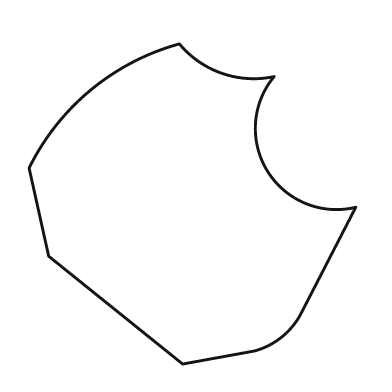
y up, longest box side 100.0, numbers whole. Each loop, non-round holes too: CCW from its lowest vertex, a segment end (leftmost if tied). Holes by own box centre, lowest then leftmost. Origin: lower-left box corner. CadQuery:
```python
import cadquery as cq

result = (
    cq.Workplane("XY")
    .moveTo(47.0, 0.0)
    .lineTo(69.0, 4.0)
    .threePointArc((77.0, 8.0), (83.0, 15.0))
    .lineTo(100.0, 48.0)
    .threePointArc((73.0, 59.0), (75.0, 88.0))
    .threePointArc((59.0, 89.0), (46.0, 98.0))
    .threePointArc((19.0, 84.0), (0.0, 60.0))
    .lineTo(6.0, 33.0)
    .close()
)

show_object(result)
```